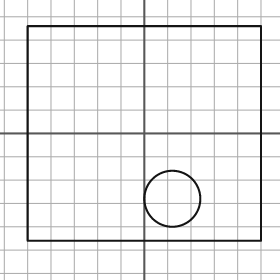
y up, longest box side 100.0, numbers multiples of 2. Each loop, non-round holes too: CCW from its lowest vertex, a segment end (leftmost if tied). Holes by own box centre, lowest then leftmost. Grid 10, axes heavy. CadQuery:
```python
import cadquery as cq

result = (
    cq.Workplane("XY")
    .moveTo(-50.0, -46.0)
    .lineTo(50.0, -46.0)
    .lineTo(50.0, 46.0)
    .lineTo(-50.0, 46.0)
    .close()
    .moveTo(12.0, -28.0)
    .circle(12.0)
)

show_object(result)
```